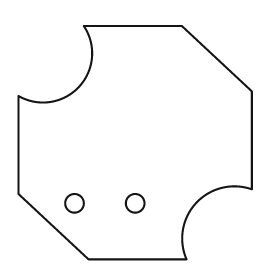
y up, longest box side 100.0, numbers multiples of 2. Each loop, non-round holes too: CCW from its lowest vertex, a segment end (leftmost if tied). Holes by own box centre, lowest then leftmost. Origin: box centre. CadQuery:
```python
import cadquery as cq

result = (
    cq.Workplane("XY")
    .moveTo(-20.0, -50.0)
    .lineTo(22.0, -50.0)
    .threePointArc((26.0, -26.0), (50.0, -20.0))
    .lineTo(50.0, 22.0)
    .lineTo(20.0, 50.0)
    .lineTo(-22.0, 50.0)
    .threePointArc((-24.0, 24.0), (-50.0, 20.0))
    .lineTo(-50.0, -22.0)
    .close()
    .moveTo(-26.0, -26.0)
    .circle(4.0)
    .moveTo(0.0, -26.0)
    .circle(4.0)
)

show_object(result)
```